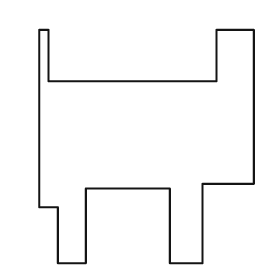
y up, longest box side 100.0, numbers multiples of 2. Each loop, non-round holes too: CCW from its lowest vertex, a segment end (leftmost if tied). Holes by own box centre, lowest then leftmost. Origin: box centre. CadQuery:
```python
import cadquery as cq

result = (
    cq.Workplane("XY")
    .moveTo(-38.0, -50.0)
    .lineTo(-26.0, -50.0)
    .lineTo(-26.0, -18.0)
    .lineTo(10.0, -18.0)
    .lineTo(10.0, -50.0)
    .lineTo(24.0, -50.0)
    .lineTo(24.0, -16.0)
    .lineTo(46.0, -16.0)
    .lineTo(46.0, 50.0)
    .lineTo(30.0, 50.0)
    .lineTo(30.0, 28.0)
    .lineTo(-42.0, 28.0)
    .lineTo(-42.0, 50.0)
    .lineTo(-46.0, 50.0)
    .lineTo(-46.0, -26.0)
    .lineTo(-38.0, -26.0)
    .close()
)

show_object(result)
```